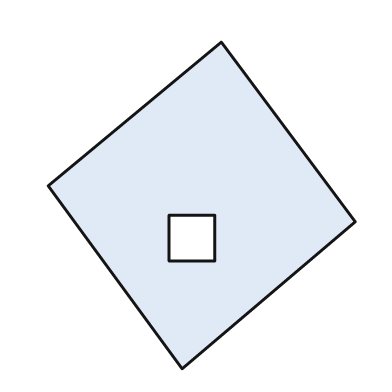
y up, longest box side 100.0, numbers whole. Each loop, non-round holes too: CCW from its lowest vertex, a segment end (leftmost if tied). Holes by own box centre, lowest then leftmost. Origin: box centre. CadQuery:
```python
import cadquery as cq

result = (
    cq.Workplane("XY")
    .moveTo(-6.0, -50.0)
    .lineTo(47.0, -5.0)
    .lineTo(6.0, 50.0)
    .lineTo(-47.0, 6.0)
    .close()
    .moveTo(-10.0, -17.0)
    .lineTo(4.0, -17.0)
    .lineTo(4.0, -3.0)
    .lineTo(-10.0, -3.0)
    .close()
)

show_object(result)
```